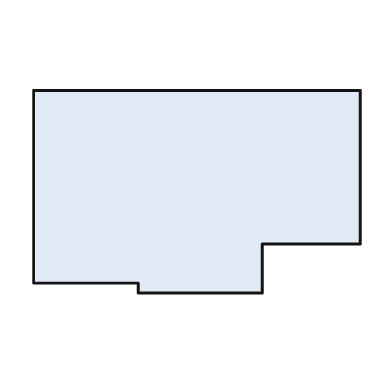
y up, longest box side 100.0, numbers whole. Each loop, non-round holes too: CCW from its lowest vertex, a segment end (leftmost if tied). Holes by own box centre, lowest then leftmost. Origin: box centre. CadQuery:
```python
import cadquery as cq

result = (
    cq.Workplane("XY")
    .moveTo(-18.0, -31.0)
    .lineTo(20.0, -31.0)
    .lineTo(20.0, -16.0)
    .lineTo(50.0, -16.0)
    .lineTo(50.0, 31.0)
    .lineTo(-50.0, 31.0)
    .lineTo(-50.0, -28.0)
    .lineTo(-18.0, -28.0)
    .close()
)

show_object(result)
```